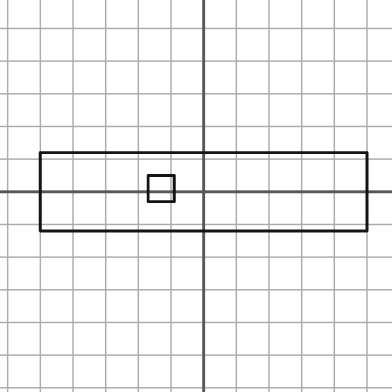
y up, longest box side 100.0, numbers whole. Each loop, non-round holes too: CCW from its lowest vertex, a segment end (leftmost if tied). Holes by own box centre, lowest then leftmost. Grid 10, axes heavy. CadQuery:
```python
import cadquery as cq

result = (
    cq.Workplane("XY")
    .moveTo(-50.0, -12.0)
    .lineTo(50.0, -12.0)
    .lineTo(50.0, 12.0)
    .lineTo(-50.0, 12.0)
    .close()
    .moveTo(-17.0, -3.0)
    .lineTo(-9.0, -3.0)
    .lineTo(-9.0, 5.0)
    .lineTo(-17.0, 5.0)
    .close()
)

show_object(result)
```